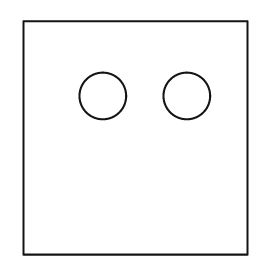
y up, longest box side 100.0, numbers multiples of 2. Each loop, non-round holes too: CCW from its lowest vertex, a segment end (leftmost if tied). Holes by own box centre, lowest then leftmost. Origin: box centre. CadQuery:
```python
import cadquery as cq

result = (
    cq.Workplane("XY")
    .moveTo(-48.0, -50.0)
    .lineTo(48.0, -50.0)
    .lineTo(48.0, 50.0)
    .lineTo(-48.0, 50.0)
    .close()
    .moveTo(-14.0, 18.0)
    .circle(10.0)
    .moveTo(22.0, 18.0)
    .circle(10.0)
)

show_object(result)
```